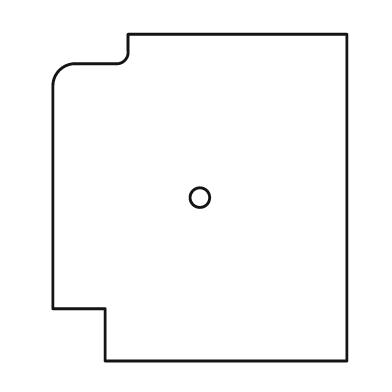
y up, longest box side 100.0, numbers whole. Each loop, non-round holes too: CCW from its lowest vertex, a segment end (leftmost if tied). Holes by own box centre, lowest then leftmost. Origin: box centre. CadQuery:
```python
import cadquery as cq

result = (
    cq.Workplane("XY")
    .moveTo(-29.0, -50.0)
    .lineTo(45.0, -50.0)
    .lineTo(45.0, 50.0)
    .lineTo(-22.0, 50.0)
    .lineTo(-22.0, 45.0)
    .threePointArc((-23.0, 42.0), (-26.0, 41.0))
    .lineTo(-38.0, 41.0)
    .threePointArc((-43.0, 39.0), (-45.0, 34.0))
    .lineTo(-45.0, -34.0)
    .lineTo(-29.0, -34.0)
    .close()
    .moveTo(0.0, 0.0)
    .circle(3.0)
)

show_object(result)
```